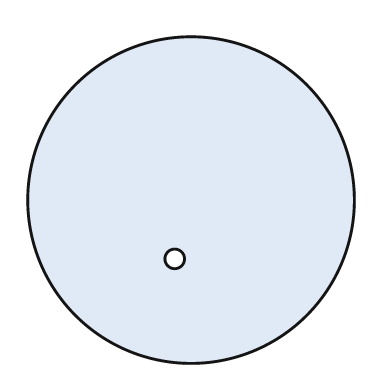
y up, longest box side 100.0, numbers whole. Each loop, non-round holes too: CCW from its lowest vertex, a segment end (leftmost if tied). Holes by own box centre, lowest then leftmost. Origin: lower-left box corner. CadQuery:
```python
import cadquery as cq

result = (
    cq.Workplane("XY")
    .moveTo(50.0, 50.0)
    .circle(50.0)
    .moveTo(45.0, 32.0)
    .circle(3.0)
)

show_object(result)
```